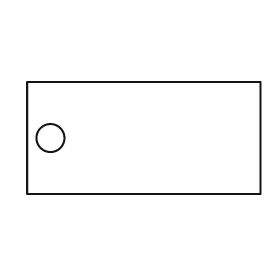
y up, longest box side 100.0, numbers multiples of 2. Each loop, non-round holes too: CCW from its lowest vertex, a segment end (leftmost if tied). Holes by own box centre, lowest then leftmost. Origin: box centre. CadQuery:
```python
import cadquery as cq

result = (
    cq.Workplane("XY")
    .moveTo(-50.0, -24.0)
    .lineTo(50.0, -24.0)
    .lineTo(50.0, 24.0)
    .lineTo(-50.0, 24.0)
    .close()
    .moveTo(-40.0, 0.0)
    .circle(6.0)
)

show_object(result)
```